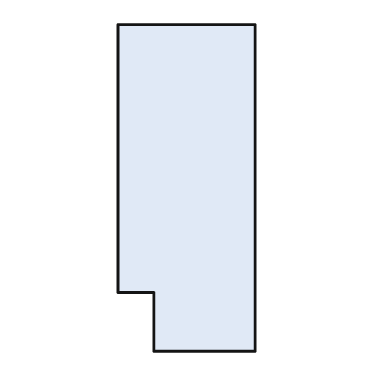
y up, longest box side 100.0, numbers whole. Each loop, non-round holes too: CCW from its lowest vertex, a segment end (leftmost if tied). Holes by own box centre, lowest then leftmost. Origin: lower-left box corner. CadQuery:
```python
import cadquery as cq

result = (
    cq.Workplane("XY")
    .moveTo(11.0, 0.0)
    .lineTo(42.0, 0.0)
    .lineTo(42.0, 100.0)
    .lineTo(0.0, 100.0)
    .lineTo(0.0, 18.0)
    .lineTo(11.0, 18.0)
    .close()
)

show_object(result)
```